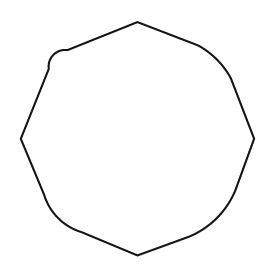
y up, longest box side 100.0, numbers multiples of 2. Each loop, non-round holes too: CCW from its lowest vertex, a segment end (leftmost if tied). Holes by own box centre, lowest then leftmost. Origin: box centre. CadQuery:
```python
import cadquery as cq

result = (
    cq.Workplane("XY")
    .moveTo(0.0, -50.0)
    .lineTo(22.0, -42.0)
    .threePointArc((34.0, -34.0), (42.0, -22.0))
    .lineTo(50.0, 0.0)
    .lineTo(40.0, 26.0)
    .threePointArc((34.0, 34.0), (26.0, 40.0))
    .lineTo(0.0, 50.0)
    .lineTo(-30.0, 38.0)
    .threePointArc((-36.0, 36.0), (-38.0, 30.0))
    .lineTo(-50.0, 0.0)
    .lineTo(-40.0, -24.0)
    .threePointArc((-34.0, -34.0), (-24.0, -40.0))
    .close()
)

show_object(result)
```